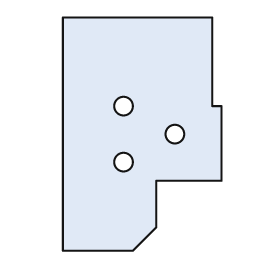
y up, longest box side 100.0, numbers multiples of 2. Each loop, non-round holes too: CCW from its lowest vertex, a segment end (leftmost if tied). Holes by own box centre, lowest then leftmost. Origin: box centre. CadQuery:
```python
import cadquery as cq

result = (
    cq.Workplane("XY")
    .moveTo(-34.0, -50.0)
    .lineTo(-4.0, -50.0)
    .lineTo(6.0, -40.0)
    .lineTo(6.0, -20.0)
    .lineTo(34.0, -20.0)
    .lineTo(34.0, 12.0)
    .lineTo(30.0, 12.0)
    .lineTo(30.0, 50.0)
    .lineTo(-34.0, 50.0)
    .close()
    .moveTo(-8.0, -12.0)
    .circle(4.0)
    .moveTo(14.0, 0.0)
    .circle(4.0)
    .moveTo(-8.0, 12.0)
    .circle(4.0)
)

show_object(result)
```